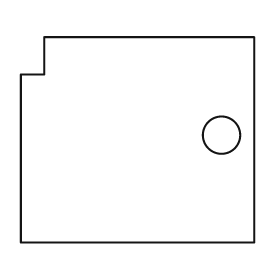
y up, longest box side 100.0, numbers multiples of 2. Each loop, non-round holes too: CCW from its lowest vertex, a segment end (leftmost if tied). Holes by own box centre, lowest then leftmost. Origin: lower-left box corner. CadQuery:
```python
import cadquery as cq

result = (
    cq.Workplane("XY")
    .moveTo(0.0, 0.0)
    .lineTo(100.0, 0.0)
    .lineTo(100.0, 88.0)
    .lineTo(10.0, 88.0)
    .lineTo(10.0, 72.0)
    .lineTo(0.0, 72.0)
    .close()
    .moveTo(86.0, 46.0)
    .circle(8.0)
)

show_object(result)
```